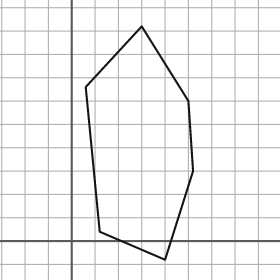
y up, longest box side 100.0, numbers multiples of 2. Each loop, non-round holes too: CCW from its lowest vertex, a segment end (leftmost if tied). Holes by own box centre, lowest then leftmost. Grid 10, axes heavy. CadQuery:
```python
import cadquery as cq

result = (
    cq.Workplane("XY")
    .moveTo(40.0, -8.0)
    .lineTo(52.0, 30.0)
    .lineTo(50.0, 60.0)
    .lineTo(30.0, 92.0)
    .lineTo(6.0, 66.0)
    .lineTo(12.0, 4.0)
    .close()
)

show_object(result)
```